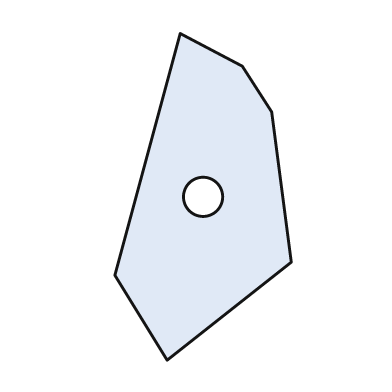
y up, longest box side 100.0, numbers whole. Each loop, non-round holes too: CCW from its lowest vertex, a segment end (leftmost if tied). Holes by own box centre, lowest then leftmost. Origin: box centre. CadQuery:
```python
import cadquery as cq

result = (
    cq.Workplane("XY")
    .moveTo(-11.0, -50.0)
    .lineTo(27.0, -20.0)
    .lineTo(21.0, 26.0)
    .lineTo(12.0, 40.0)
    .lineTo(-7.0, 50.0)
    .lineTo(-27.0, -24.0)
    .close()
    .moveTo(0.0, 0.0)
    .circle(6.0)
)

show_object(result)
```